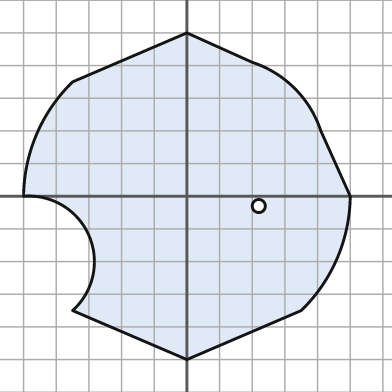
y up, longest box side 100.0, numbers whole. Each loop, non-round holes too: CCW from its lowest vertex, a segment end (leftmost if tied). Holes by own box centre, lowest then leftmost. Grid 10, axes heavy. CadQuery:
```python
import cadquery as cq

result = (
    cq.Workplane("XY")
    .moveTo(0.0, -50.0)
    .lineTo(35.0, -35.0)
    .threePointArc((46.0, -19.0), (50.0, 0.0))
    .lineTo(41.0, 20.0)
    .threePointArc((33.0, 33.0), (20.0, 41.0))
    .lineTo(0.0, 50.0)
    .lineTo(-35.0, 35.0)
    .threePointArc((-46.0, 19.0), (-50.0, 0.0))
    .threePointArc((-30.0, -12.0), (-35.0, -35.0))
    .close()
    .moveTo(22.0, -3.0)
    .circle(2.0)
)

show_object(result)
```